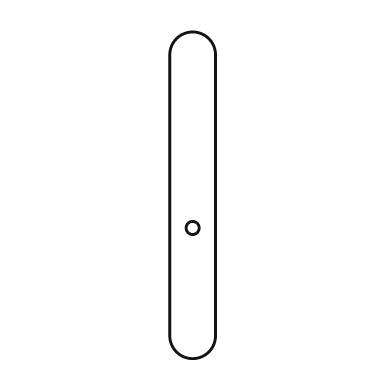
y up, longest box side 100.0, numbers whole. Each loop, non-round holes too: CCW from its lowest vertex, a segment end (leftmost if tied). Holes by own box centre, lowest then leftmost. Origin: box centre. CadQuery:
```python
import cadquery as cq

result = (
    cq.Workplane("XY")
    .moveTo(-7.0, -43.0)
    .threePointArc((0.0, -50.0), (7.0, -43.0))
    .lineTo(7.0, 43.0)
    .threePointArc((0.0, 50.0), (-7.0, 43.0))
    .close()
    .moveTo(0.0, -10.0)
    .circle(2.0)
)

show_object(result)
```